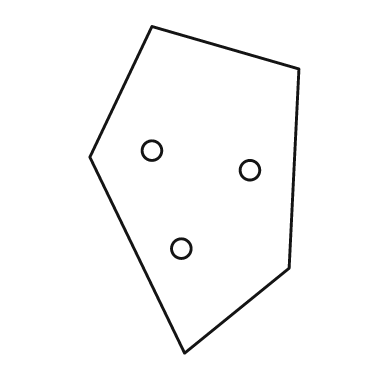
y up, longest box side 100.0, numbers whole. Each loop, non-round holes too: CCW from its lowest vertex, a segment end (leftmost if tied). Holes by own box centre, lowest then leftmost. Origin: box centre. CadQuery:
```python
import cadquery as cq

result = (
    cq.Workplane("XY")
    .moveTo(-3.0, -50.0)
    .lineTo(29.0, -24.0)
    .lineTo(32.0, 37.0)
    .lineTo(-13.0, 50.0)
    .lineTo(-32.0, 10.0)
    .close()
    .moveTo(-4.0, -18.0)
    .circle(3.0)
    .moveTo(17.0, 6.0)
    .circle(3.0)
    .moveTo(-13.0, 12.0)
    .circle(3.0)
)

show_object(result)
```